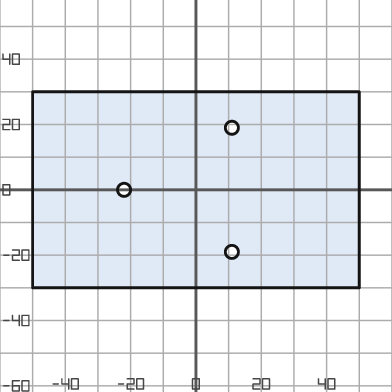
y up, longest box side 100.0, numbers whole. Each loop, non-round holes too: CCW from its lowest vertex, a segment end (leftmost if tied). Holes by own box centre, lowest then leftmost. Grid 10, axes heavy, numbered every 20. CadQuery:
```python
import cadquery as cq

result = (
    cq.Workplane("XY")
    .moveTo(-50.0, -30.0)
    .lineTo(50.0, -30.0)
    .lineTo(50.0, 30.0)
    .lineTo(-50.0, 30.0)
    .close()
    .moveTo(11.0, -19.0)
    .circle(2.0)
    .moveTo(-22.0, 0.0)
    .circle(2.0)
    .moveTo(11.0, 19.0)
    .circle(2.0)
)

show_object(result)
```